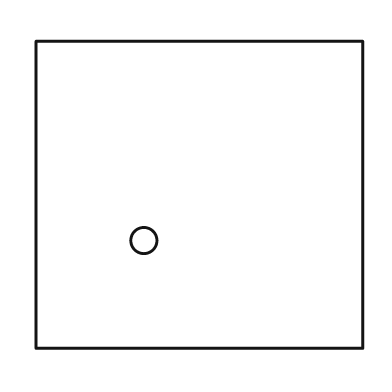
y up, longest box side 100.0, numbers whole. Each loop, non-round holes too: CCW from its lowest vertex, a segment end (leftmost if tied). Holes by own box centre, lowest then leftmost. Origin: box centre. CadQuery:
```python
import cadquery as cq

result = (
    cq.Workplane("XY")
    .moveTo(-50.0, -47.0)
    .lineTo(50.0, -47.0)
    .lineTo(50.0, 47.0)
    .lineTo(-50.0, 47.0)
    .close()
    .moveTo(-17.0, -14.0)
    .circle(4.0)
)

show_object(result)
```